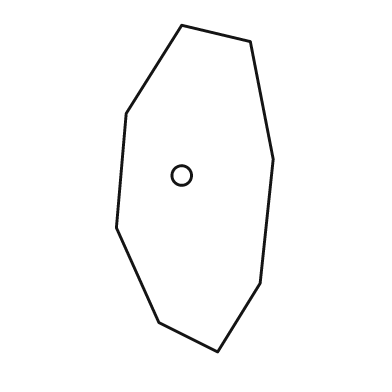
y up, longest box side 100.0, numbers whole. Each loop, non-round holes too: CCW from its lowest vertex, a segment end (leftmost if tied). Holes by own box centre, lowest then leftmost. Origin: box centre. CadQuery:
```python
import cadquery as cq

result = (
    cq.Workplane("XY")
    .moveTo(7.0, -50.0)
    .lineTo(20.0, -29.0)
    .lineTo(24.0, 9.0)
    .lineTo(17.0, 45.0)
    .lineTo(-4.0, 50.0)
    .lineTo(-21.0, 23.0)
    .lineTo(-24.0, -12.0)
    .lineTo(-11.0, -41.0)
    .close()
    .moveTo(-4.0, 4.0)
    .circle(3.0)
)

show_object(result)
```